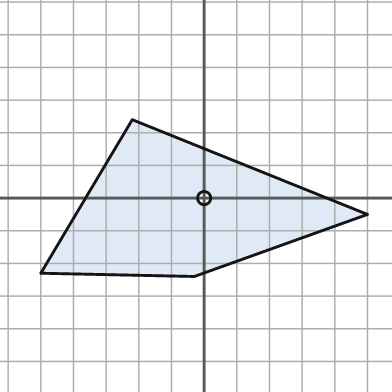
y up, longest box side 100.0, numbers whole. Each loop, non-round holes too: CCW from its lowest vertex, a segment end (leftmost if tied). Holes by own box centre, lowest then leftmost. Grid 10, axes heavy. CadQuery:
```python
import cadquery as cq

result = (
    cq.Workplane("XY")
    .moveTo(-3.0, -24.0)
    .lineTo(50.0, -5.0)
    .lineTo(-22.0, 24.0)
    .lineTo(-50.0, -23.0)
    .close()
    .moveTo(0.0, 0.0)
    .circle(2.0)
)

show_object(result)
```